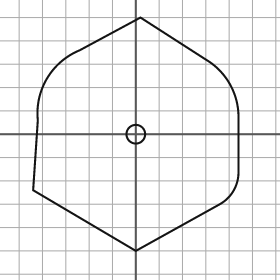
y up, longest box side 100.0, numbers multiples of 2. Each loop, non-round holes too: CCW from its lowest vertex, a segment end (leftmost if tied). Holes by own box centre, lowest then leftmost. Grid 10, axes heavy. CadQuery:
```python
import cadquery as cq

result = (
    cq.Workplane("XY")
    .moveTo(0.0, -50.0)
    .lineTo(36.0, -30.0)
    .threePointArc((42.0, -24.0), (44.0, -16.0))
    .lineTo(44.0, 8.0)
    .threePointArc((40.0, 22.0), (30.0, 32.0))
    .lineTo(2.0, 50.0)
    .lineTo(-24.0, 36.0)
    .threePointArc((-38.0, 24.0), (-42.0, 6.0))
    .lineTo(-44.0, -24.0)
    .close()
    .moveTo(0.0, 0.0)
    .circle(4.0)
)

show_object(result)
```